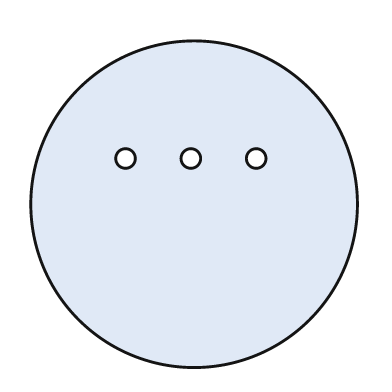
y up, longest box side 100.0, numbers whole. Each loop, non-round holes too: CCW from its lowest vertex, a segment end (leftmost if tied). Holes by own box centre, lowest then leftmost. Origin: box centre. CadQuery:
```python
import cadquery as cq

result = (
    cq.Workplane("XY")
    .moveTo(0.0, 0.0)
    .circle(50.0)
    .moveTo(-21.0, 14.0)
    .circle(3.0)
    .moveTo(-1.0, 14.0)
    .circle(3.0)
    .moveTo(19.0, 14.0)
    .circle(3.0)
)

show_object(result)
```